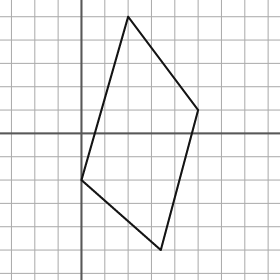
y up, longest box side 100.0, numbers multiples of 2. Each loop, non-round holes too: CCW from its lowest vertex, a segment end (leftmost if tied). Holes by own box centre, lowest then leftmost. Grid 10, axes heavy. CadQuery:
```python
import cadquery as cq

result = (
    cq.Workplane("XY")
    .moveTo(34.0, -50.0)
    .lineTo(50.0, 10.0)
    .lineTo(20.0, 50.0)
    .lineTo(0.0, -20.0)
    .close()
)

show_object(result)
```